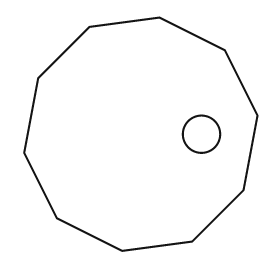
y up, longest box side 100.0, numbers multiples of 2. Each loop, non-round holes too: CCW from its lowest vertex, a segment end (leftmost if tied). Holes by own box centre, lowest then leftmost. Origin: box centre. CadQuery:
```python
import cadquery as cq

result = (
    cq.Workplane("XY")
    .moveTo(-8.0, -50.0)
    .lineTo(22.0, -46.0)
    .lineTo(44.0, -24.0)
    .lineTo(50.0, 8.0)
    .lineTo(36.0, 36.0)
    .lineTo(8.0, 50.0)
    .lineTo(-22.0, 46.0)
    .lineTo(-44.0, 24.0)
    .lineTo(-50.0, -8.0)
    .lineTo(-36.0, -36.0)
    .close()
    .moveTo(26.0, 0.0)
    .circle(8.0)
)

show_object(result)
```